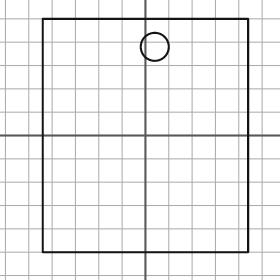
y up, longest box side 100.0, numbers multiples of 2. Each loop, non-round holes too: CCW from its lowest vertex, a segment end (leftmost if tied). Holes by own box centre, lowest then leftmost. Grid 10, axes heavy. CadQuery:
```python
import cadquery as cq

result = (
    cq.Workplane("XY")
    .moveTo(-44.0, -50.0)
    .lineTo(44.0, -50.0)
    .lineTo(44.0, 50.0)
    .lineTo(-44.0, 50.0)
    .close()
    .moveTo(4.0, 38.0)
    .circle(6.0)
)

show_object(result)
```